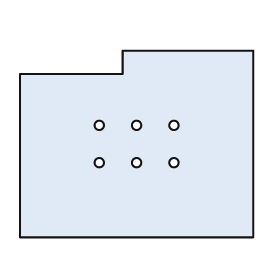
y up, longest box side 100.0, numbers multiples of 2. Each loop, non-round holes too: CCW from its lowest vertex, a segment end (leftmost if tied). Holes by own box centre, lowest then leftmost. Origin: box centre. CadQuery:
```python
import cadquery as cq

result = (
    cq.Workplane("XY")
    .moveTo(-50.0, -40.0)
    .lineTo(50.0, -40.0)
    .lineTo(50.0, 40.0)
    .lineTo(-6.0, 40.0)
    .lineTo(-6.0, 30.0)
    .lineTo(-50.0, 30.0)
    .close()
    .moveTo(-16.0, -8.0)
    .circle(2.0)
    .moveTo(0.0, -8.0)
    .circle(2.0)
    .moveTo(16.0, -8.0)
    .circle(2.0)
    .moveTo(-16.0, 8.0)
    .circle(2.0)
    .moveTo(0.0, 8.0)
    .circle(2.0)
    .moveTo(16.0, 8.0)
    .circle(2.0)
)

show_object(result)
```